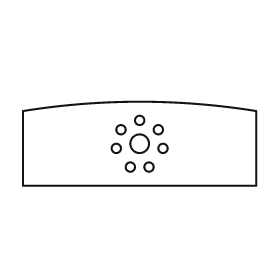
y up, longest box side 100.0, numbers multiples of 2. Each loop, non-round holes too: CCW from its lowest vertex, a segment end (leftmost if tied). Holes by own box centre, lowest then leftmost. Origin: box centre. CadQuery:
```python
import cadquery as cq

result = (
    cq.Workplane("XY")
    .moveTo(-50.0, -18.0)
    .lineTo(50.0, -18.0)
    .lineTo(50.0, 14.0)
    .threePointArc((0.0, 18.0), (-50.0, 14.0))
    .close()
    .moveTo(-4.0, -10.0)
    .circle(2.0)
    .moveTo(4.0, -10.0)
    .circle(2.0)
    .moveTo(-10.0, -2.0)
    .circle(2.0)
    .moveTo(10.0, -2.0)
    .circle(2.0)
    .moveTo(0.0, 0.0)
    .circle(4.0)
    .moveTo(-8.0, 6.0)
    .circle(2.0)
    .moveTo(8.0, 6.0)
    .circle(2.0)
    .moveTo(0.0, 10.0)
    .circle(2.0)
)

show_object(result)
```